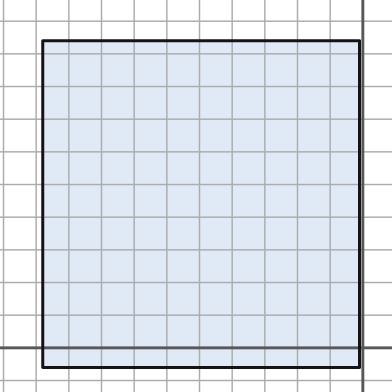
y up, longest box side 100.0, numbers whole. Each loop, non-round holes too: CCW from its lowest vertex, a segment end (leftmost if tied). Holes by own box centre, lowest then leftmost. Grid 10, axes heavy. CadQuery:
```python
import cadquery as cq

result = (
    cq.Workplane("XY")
    .moveTo(-98.0, -6.0)
    .lineTo(-1.0, -6.0)
    .lineTo(-1.0, 94.0)
    .lineTo(-98.0, 94.0)
    .close()
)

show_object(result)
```